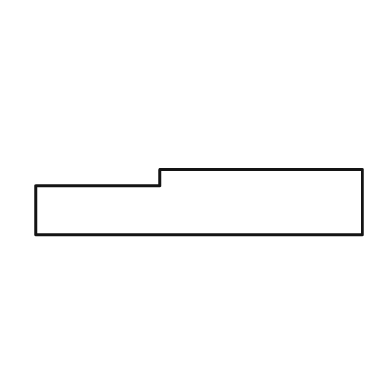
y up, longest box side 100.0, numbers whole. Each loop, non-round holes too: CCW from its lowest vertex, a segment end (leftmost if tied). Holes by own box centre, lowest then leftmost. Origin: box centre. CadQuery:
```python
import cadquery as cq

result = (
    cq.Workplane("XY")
    .moveTo(-50.0, -10.0)
    .lineTo(50.0, -10.0)
    .lineTo(50.0, 10.0)
    .lineTo(-12.0, 10.0)
    .lineTo(-12.0, 5.0)
    .lineTo(-50.0, 5.0)
    .close()
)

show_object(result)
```